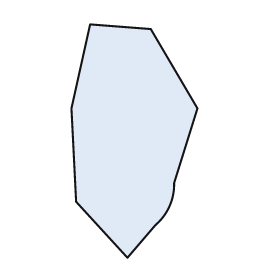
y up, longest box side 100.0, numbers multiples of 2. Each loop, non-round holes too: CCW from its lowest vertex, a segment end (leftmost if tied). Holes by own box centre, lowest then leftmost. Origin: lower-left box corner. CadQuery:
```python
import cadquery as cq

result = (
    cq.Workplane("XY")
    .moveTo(24.0, 0.0)
    .lineTo(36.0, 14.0)
    .threePointArc((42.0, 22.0), (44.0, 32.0))
    .lineTo(54.0, 64.0)
    .lineTo(34.0, 98.0)
    .lineTo(8.0, 100.0)
    .lineTo(0.0, 64.0)
    .lineTo(2.0, 24.0)
    .close()
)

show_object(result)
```